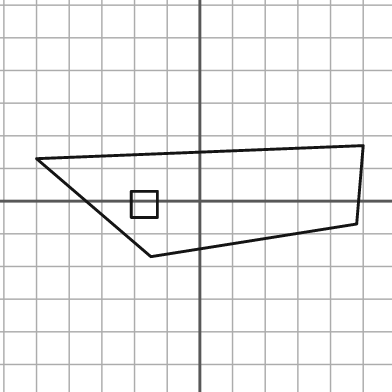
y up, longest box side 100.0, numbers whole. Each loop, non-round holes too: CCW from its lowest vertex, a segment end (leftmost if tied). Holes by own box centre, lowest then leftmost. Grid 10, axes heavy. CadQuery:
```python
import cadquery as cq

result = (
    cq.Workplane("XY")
    .moveTo(-15.0, -17.0)
    .lineTo(48.0, -7.0)
    .lineTo(50.0, 17.0)
    .lineTo(-50.0, 13.0)
    .close()
    .moveTo(-21.0, -5.0)
    .lineTo(-13.0, -5.0)
    .lineTo(-13.0, 3.0)
    .lineTo(-21.0, 3.0)
    .close()
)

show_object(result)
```